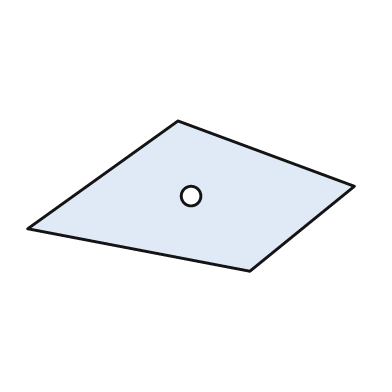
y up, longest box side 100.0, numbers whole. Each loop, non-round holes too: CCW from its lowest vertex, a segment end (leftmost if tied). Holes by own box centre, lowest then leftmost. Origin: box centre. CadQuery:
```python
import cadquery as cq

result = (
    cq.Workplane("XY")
    .moveTo(18.0, -23.0)
    .lineTo(50.0, 3.0)
    .lineTo(-4.0, 23.0)
    .lineTo(-50.0, -10.0)
    .close()
    .moveTo(0.0, 0.0)
    .circle(3.0)
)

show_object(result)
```